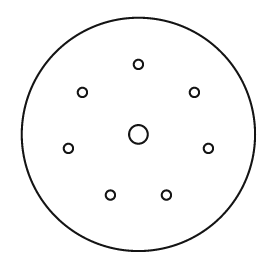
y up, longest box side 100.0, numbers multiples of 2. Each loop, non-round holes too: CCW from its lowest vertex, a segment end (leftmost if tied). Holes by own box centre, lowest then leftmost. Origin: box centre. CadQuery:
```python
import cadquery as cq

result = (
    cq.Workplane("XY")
    .moveTo(0.0, 0.0)
    .circle(50.0)
    .moveTo(-12.0, -26.0)
    .circle(2.0)
    .moveTo(12.0, -26.0)
    .circle(2.0)
    .moveTo(-30.0, -6.0)
    .circle(2.0)
    .moveTo(30.0, -6.0)
    .circle(2.0)
    .moveTo(0.0, 0.0)
    .circle(4.0)
    .moveTo(-24.0, 18.0)
    .circle(2.0)
    .moveTo(24.0, 18.0)
    .circle(2.0)
    .moveTo(0.0, 30.0)
    .circle(2.0)
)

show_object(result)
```